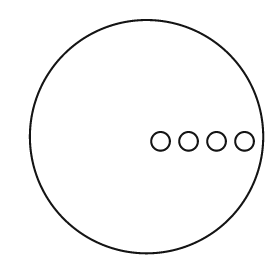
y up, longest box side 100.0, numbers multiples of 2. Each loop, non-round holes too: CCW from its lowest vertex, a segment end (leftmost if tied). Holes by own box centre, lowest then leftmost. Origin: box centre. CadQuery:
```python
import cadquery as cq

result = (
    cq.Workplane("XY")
    .moveTo(0.0, 0.0)
    .circle(50.0)
    .moveTo(6.0, -2.0)
    .circle(4.0)
    .moveTo(18.0, -2.0)
    .circle(4.0)
    .moveTo(30.0, -2.0)
    .circle(4.0)
    .moveTo(42.0, -2.0)
    .circle(4.0)
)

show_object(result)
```